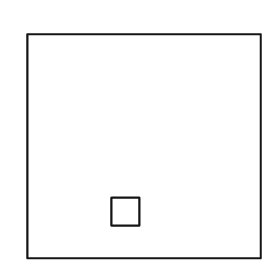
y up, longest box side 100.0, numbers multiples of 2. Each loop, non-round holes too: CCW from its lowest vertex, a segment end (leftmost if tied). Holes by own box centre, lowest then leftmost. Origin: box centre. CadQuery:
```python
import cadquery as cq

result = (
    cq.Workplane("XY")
    .moveTo(-50.0, -48.0)
    .lineTo(50.0, -48.0)
    .lineTo(50.0, 48.0)
    .lineTo(-50.0, 48.0)
    .close()
    .moveTo(-14.0, -34.0)
    .lineTo(-2.0, -34.0)
    .lineTo(-2.0, -22.0)
    .lineTo(-14.0, -22.0)
    .close()
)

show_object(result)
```